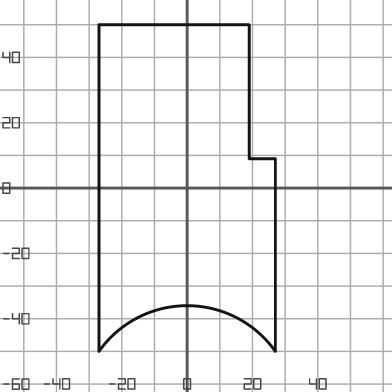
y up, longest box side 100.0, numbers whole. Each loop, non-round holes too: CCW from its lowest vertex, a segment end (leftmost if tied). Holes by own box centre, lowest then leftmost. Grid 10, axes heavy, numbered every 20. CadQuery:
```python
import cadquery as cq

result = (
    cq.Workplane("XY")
    .moveTo(-27.0, -50.0)
    .threePointArc((0.0, -36.0), (27.0, -50.0))
    .lineTo(27.0, 9.0)
    .lineTo(19.0, 9.0)
    .lineTo(19.0, 50.0)
    .lineTo(-27.0, 50.0)
    .close()
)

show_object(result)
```